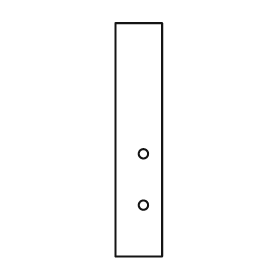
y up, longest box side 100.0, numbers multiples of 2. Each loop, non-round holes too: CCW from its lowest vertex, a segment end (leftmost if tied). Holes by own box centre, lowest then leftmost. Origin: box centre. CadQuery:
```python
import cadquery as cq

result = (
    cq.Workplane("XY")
    .moveTo(-10.0, -50.0)
    .lineTo(10.0, -50.0)
    .lineTo(10.0, 50.0)
    .lineTo(-10.0, 50.0)
    .close()
    .moveTo(2.0, -28.0)
    .circle(2.0)
    .moveTo(2.0, -6.0)
    .circle(2.0)
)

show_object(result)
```